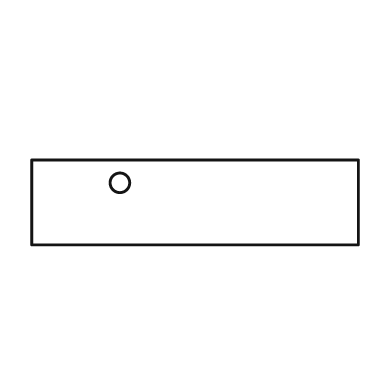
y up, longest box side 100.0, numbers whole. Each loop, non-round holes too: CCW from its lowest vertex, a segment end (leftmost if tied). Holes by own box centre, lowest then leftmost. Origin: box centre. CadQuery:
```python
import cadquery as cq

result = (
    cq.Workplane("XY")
    .moveTo(-50.0, -13.0)
    .lineTo(50.0, -13.0)
    .lineTo(50.0, 13.0)
    .lineTo(-50.0, 13.0)
    .close()
    .moveTo(-23.0, 6.0)
    .circle(3.0)
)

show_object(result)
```